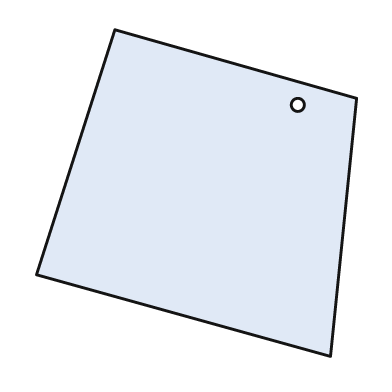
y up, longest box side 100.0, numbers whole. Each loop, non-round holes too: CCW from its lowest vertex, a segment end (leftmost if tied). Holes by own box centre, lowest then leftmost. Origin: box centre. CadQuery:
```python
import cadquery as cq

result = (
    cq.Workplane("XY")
    .moveTo(41.0, -50.0)
    .lineTo(49.0, 29.0)
    .lineTo(-25.0, 50.0)
    .lineTo(-49.0, -25.0)
    .close()
    .moveTo(31.0, 27.0)
    .circle(2.0)
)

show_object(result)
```